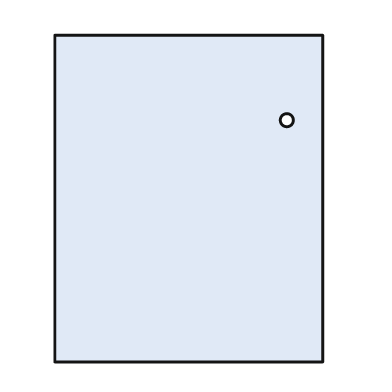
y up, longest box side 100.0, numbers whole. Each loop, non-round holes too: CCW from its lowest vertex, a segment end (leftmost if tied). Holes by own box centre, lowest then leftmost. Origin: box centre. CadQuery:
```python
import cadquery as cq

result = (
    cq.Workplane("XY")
    .moveTo(-41.0, -50.0)
    .lineTo(41.0, -50.0)
    .lineTo(41.0, 50.0)
    .lineTo(-41.0, 50.0)
    .close()
    .moveTo(30.0, 24.0)
    .circle(2.0)
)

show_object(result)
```